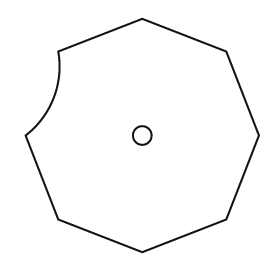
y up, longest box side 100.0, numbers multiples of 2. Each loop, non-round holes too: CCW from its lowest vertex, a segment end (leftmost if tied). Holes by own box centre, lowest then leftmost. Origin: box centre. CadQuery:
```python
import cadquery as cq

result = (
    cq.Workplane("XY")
    .moveTo(0.0, -50.0)
    .lineTo(36.0, -36.0)
    .lineTo(50.0, 0.0)
    .lineTo(36.0, 36.0)
    .lineTo(0.0, 50.0)
    .lineTo(-36.0, 36.0)
    .threePointArc((-38.0, 16.0), (-50.0, 0.0))
    .lineTo(-36.0, -36.0)
    .close()
    .moveTo(0.0, 0.0)
    .circle(4.0)
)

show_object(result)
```